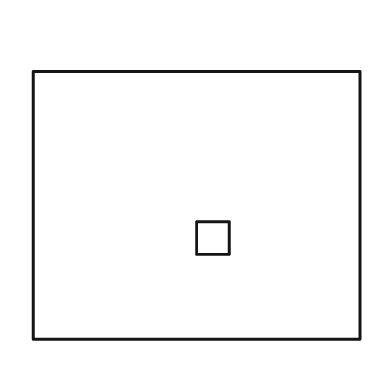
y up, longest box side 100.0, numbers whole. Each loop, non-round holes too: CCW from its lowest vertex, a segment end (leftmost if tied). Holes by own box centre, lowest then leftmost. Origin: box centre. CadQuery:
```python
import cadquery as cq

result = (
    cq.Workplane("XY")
    .moveTo(-50.0, -41.0)
    .lineTo(50.0, -41.0)
    .lineTo(50.0, 41.0)
    .lineTo(-50.0, 41.0)
    .close()
    .moveTo(0.0, -15.0)
    .lineTo(10.0, -15.0)
    .lineTo(10.0, -5.0)
    .lineTo(0.0, -5.0)
    .close()
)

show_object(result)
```